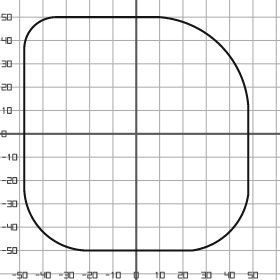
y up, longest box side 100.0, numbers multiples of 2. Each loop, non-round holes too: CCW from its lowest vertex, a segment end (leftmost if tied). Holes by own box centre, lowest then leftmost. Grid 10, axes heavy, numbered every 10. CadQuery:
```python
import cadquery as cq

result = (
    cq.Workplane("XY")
    .moveTo(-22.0, -50.0)
    .lineTo(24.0, -50.0)
    .threePointArc((40.0, -42.0), (48.0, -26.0))
    .lineTo(48.0, 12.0)
    .threePointArc((36.0, 38.0), (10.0, 50.0))
    .lineTo(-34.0, 50.0)
    .threePointArc((-44.0, 46.0), (-48.0, 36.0))
    .lineTo(-48.0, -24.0)
    .threePointArc((-40.0, -42.0), (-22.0, -50.0))
    .close()
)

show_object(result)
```